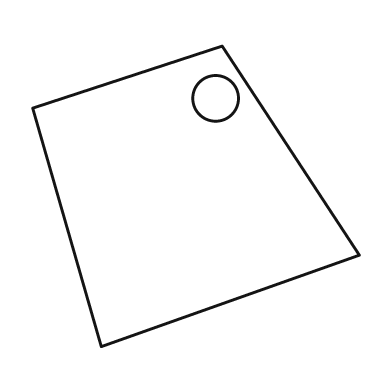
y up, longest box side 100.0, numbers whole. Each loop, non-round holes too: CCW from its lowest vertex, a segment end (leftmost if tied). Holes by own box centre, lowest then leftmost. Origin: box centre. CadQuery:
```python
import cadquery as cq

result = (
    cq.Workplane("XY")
    .moveTo(-29.0, -46.0)
    .lineTo(50.0, -18.0)
    .lineTo(8.0, 46.0)
    .lineTo(-50.0, 27.0)
    .close()
    .moveTo(6.0, 30.0)
    .circle(7.0)
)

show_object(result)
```